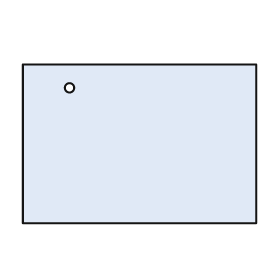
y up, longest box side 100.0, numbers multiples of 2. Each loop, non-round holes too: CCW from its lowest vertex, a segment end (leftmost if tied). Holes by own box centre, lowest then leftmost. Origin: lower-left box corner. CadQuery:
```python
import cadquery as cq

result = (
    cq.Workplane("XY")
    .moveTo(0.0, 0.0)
    .lineTo(100.0, 0.0)
    .lineTo(100.0, 68.0)
    .lineTo(0.0, 68.0)
    .close()
    .moveTo(20.0, 58.0)
    .circle(2.0)
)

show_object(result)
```